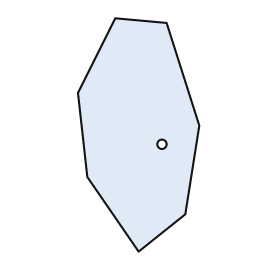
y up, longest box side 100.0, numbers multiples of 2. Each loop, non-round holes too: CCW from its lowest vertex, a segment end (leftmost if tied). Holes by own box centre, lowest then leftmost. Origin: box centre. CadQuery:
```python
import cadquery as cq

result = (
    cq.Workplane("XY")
    .moveTo(0.0, -50.0)
    .lineTo(20.0, -34.0)
    .lineTo(26.0, 4.0)
    .lineTo(12.0, 48.0)
    .lineTo(-10.0, 50.0)
    .lineTo(-26.0, 18.0)
    .lineTo(-22.0, -18.0)
    .close()
    .moveTo(10.0, -4.0)
    .circle(2.0)
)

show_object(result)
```